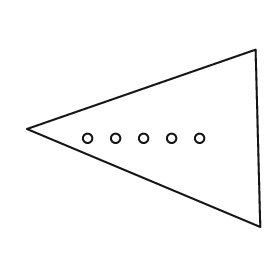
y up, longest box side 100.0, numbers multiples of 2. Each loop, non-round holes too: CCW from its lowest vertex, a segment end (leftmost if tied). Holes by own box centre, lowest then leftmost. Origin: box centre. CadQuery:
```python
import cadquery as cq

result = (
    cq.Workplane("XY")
    .moveTo(50.0, -38.0)
    .lineTo(48.0, 38.0)
    .lineTo(-50.0, 4.0)
    .close()
    .moveTo(-24.0, 0.0)
    .circle(2.0)
    .moveTo(-12.0, 0.0)
    .circle(2.0)
    .moveTo(0.0, 0.0)
    .circle(2.0)
    .moveTo(12.0, 0.0)
    .circle(2.0)
    .moveTo(24.0, 0.0)
    .circle(2.0)
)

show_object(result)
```